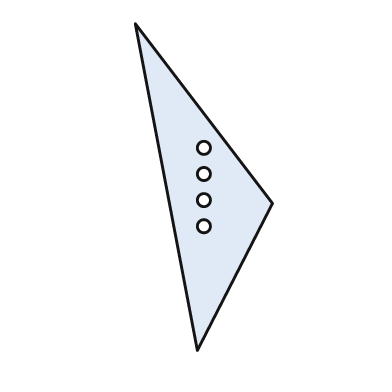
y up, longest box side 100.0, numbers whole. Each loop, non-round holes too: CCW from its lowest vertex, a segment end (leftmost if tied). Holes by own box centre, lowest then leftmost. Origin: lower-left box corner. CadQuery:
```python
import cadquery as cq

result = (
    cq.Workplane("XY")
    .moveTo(19.0, 0.0)
    .lineTo(42.0, 45.0)
    .lineTo(0.0, 100.0)
    .close()
    .moveTo(21.0, 38.0)
    .circle(2.0)
    .moveTo(21.0, 46.0)
    .circle(2.0)
    .moveTo(21.0, 54.0)
    .circle(2.0)
    .moveTo(21.0, 62.0)
    .circle(2.0)
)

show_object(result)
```